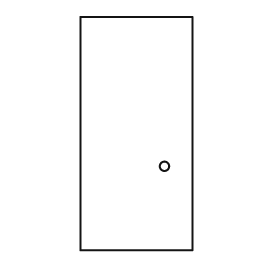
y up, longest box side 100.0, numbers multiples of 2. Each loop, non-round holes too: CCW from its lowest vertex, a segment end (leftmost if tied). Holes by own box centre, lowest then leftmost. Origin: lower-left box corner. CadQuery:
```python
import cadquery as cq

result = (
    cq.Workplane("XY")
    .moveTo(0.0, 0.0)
    .lineTo(48.0, 0.0)
    .lineTo(48.0, 100.0)
    .lineTo(0.0, 100.0)
    .close()
    .moveTo(36.0, 36.0)
    .circle(2.0)
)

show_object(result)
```